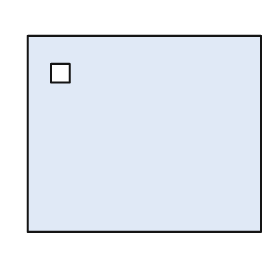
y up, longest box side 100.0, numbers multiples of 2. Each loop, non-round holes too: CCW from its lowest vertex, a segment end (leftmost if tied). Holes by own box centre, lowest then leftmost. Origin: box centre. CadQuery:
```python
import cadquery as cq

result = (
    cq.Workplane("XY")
    .moveTo(-50.0, -42.0)
    .lineTo(50.0, -42.0)
    .lineTo(50.0, 42.0)
    .lineTo(-50.0, 42.0)
    .close()
    .moveTo(-40.0, 22.0)
    .lineTo(-32.0, 22.0)
    .lineTo(-32.0, 30.0)
    .lineTo(-40.0, 30.0)
    .close()
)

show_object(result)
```